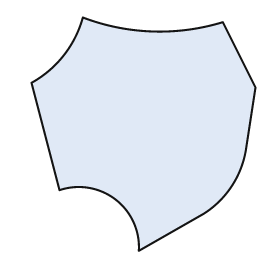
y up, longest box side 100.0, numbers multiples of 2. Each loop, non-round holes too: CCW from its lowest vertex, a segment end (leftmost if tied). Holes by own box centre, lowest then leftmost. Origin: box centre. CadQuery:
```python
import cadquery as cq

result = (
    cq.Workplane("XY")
    .moveTo(-2.0, -50.0)
    .lineTo(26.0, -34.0)
    .threePointArc((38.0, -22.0), (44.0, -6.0))
    .lineTo(48.0, 20.0)
    .lineTo(34.0, 48.0)
    .threePointArc((4.0, 44.0), (-26.0, 50.0))
    .threePointArc((-34.0, 34.0), (-48.0, 22.0))
    .lineTo(-36.0, -24.0)
    .threePointArc((-12.0, -28.0), (-2.0, -50.0))
    .close()
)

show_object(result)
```